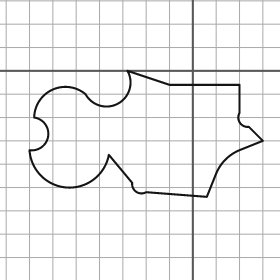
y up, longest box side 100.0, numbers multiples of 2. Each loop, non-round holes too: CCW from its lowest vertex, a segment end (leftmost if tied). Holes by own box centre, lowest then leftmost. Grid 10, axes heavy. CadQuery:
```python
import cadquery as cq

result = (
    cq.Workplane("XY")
    .moveTo(6.0, -54.0)
    .lineTo(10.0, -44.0)
    .threePointArc((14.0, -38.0), (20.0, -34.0))
    .lineTo(30.0, -30.0)
    .lineTo(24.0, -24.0)
    .threePointArc((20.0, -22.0), (20.0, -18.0))
    .lineTo(20.0, -6.0)
    .lineTo(-10.0, -6.0)
    .lineTo(-28.0, 0.0)
    .threePointArc((-32.0, -14.0), (-46.0, -10.0))
    .threePointArc((-60.0, -8.0), (-68.0, -20.0))
    .threePointArc((-62.0, -28.0), (-70.0, -34.0))
    .threePointArc((-54.0, -50.0), (-36.0, -36.0))
    .lineTo(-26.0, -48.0)
    .threePointArc((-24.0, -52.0), (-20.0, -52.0))
    .close()
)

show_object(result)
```